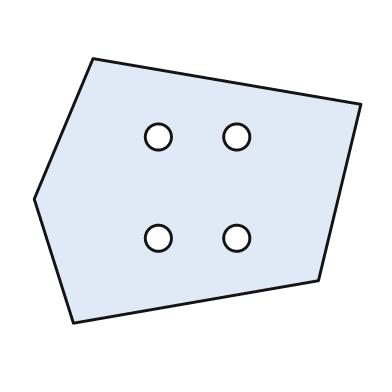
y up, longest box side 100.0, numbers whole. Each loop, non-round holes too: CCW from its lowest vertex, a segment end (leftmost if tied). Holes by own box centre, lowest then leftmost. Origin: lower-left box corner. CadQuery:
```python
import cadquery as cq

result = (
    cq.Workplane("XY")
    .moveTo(12.0, 0.0)
    .lineTo(87.0, 13.0)
    .lineTo(100.0, 67.0)
    .lineTo(18.0, 81.0)
    .lineTo(0.0, 38.0)
    .close()
    .moveTo(38.0, 26.0)
    .circle(4.0)
    .moveTo(62.0, 26.0)
    .circle(4.0)
    .moveTo(38.0, 57.0)
    .circle(4.0)
    .moveTo(62.0, 57.0)
    .circle(4.0)
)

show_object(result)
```